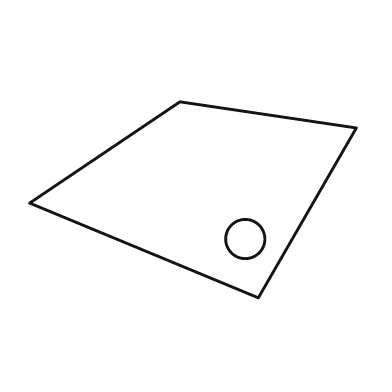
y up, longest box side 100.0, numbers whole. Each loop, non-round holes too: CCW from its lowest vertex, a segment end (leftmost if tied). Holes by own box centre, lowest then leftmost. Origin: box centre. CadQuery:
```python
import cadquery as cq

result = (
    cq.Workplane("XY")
    .moveTo(20.0, -30.0)
    .lineTo(50.0, 22.0)
    .lineTo(-4.0, 30.0)
    .lineTo(-50.0, -1.0)
    .close()
    .moveTo(16.0, -12.0)
    .circle(6.0)
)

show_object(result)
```